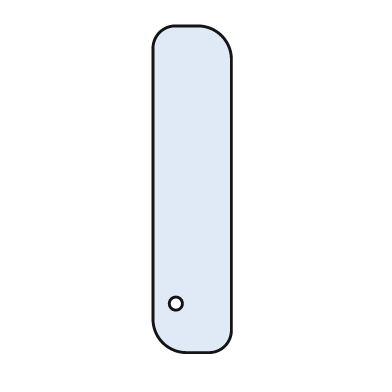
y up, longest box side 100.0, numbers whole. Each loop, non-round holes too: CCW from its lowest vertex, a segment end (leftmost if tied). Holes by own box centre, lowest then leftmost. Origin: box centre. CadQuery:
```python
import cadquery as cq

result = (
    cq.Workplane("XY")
    .moveTo(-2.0, -50.0)
    .lineTo(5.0, -50.0)
    .threePointArc((10.0, -48.0), (12.0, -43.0))
    .lineTo(12.0, 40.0)
    .threePointArc((9.0, 47.0), (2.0, 50.0))
    .lineTo(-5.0, 50.0)
    .threePointArc((-10.0, 48.0), (-12.0, 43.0))
    .lineTo(-12.0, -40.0)
    .threePointArc((-9.0, -47.0), (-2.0, -50.0))
    .close()
    .moveTo(-5.0, -35.0)
    .circle(2.0)
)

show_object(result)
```